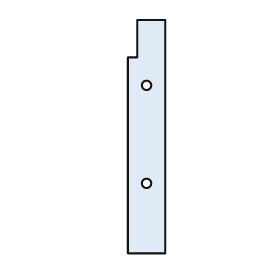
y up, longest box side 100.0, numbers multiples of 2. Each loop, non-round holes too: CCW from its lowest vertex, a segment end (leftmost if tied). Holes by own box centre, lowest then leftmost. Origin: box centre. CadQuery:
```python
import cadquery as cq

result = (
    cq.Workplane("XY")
    .moveTo(-8.0, -50.0)
    .lineTo(8.0, -50.0)
    .lineTo(8.0, 50.0)
    .lineTo(-4.0, 50.0)
    .lineTo(-4.0, 34.0)
    .lineTo(-8.0, 34.0)
    .close()
    .moveTo(0.0, -20.0)
    .circle(2.0)
    .moveTo(0.0, 22.0)
    .circle(2.0)
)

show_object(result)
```